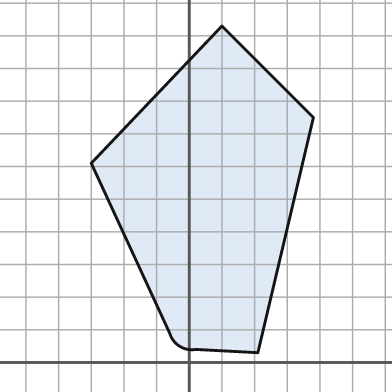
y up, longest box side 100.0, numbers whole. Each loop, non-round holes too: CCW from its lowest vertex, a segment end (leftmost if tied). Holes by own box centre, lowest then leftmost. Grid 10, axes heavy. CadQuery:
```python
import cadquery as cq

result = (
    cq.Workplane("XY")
    .moveTo(21.0, 3.0)
    .lineTo(38.0, 75.0)
    .lineTo(10.0, 103.0)
    .lineTo(-30.0, 61.0)
    .lineTo(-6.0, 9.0)
    .threePointArc((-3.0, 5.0), (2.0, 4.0))
    .close()
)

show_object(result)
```